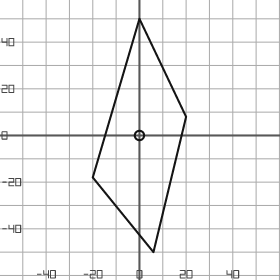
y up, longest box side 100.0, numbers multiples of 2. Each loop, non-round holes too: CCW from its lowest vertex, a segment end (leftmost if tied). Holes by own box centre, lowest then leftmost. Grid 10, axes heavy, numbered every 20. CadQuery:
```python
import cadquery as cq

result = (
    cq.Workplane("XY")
    .moveTo(6.0, -50.0)
    .lineTo(20.0, 8.0)
    .lineTo(0.0, 50.0)
    .lineTo(-20.0, -18.0)
    .close()
    .moveTo(0.0, 0.0)
    .circle(2.0)
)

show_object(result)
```